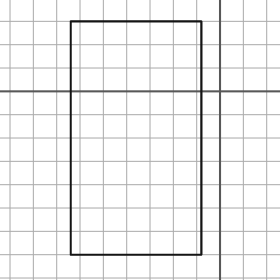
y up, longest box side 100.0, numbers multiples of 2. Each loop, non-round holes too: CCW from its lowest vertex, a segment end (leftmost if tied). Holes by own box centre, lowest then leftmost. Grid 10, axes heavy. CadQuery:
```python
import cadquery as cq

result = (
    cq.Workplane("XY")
    .moveTo(-64.0, -70.0)
    .lineTo(-8.0, -70.0)
    .lineTo(-8.0, 30.0)
    .lineTo(-64.0, 30.0)
    .close()
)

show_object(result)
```